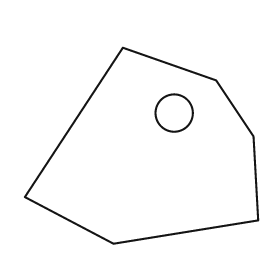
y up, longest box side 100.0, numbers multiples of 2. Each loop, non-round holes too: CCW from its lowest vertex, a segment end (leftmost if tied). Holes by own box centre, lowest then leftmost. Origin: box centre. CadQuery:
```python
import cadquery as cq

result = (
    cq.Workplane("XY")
    .moveTo(-12.0, -42.0)
    .lineTo(50.0, -32.0)
    .lineTo(48.0, 4.0)
    .lineTo(32.0, 28.0)
    .lineTo(-8.0, 42.0)
    .lineTo(-50.0, -22.0)
    .close()
    .moveTo(14.0, 14.0)
    .circle(8.0)
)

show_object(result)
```